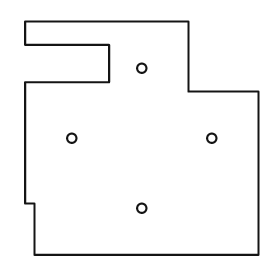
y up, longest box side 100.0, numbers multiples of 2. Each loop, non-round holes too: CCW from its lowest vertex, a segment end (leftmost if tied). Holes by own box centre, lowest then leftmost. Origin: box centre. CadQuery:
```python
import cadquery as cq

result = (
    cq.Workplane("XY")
    .moveTo(-46.0, -50.0)
    .lineTo(50.0, -50.0)
    .lineTo(50.0, 20.0)
    .lineTo(20.0, 20.0)
    .lineTo(20.0, 50.0)
    .lineTo(-50.0, 50.0)
    .lineTo(-50.0, 40.0)
    .lineTo(-14.0, 40.0)
    .lineTo(-14.0, 24.0)
    .lineTo(-50.0, 24.0)
    .lineTo(-50.0, -28.0)
    .lineTo(-46.0, -28.0)
    .close()
    .moveTo(0.0, -30.0)
    .circle(2.0)
    .moveTo(-30.0, 0.0)
    .circle(2.0)
    .moveTo(30.0, 0.0)
    .circle(2.0)
    .moveTo(0.0, 30.0)
    .circle(2.0)
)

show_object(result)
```